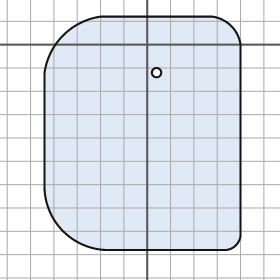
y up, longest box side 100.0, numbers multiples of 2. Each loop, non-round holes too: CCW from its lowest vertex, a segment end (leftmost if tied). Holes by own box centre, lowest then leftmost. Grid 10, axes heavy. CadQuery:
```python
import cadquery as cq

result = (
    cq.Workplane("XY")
    .moveTo(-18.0, -88.0)
    .lineTo(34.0, -88.0)
    .threePointArc((38.0, -86.0), (40.0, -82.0))
    .lineTo(40.0, 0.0)
    .threePointArc((36.0, 8.0), (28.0, 12.0))
    .lineTo(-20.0, 12.0)
    .threePointArc((-36.0, 4.0), (-44.0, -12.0))
    .lineTo(-44.0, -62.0)
    .threePointArc((-36.0, -80.0), (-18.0, -88.0))
    .close()
    .moveTo(4.0, -12.0)
    .circle(2.0)
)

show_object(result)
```